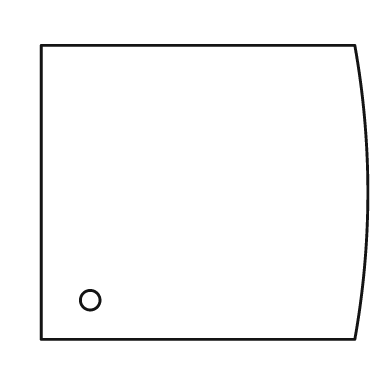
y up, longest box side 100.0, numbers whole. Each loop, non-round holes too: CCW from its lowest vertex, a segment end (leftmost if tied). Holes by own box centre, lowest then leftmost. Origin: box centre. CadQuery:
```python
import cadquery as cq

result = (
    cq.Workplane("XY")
    .moveTo(-50.0, -45.0)
    .lineTo(46.0, -45.0)
    .threePointArc((50.0, 0.0), (46.0, 45.0))
    .lineTo(-50.0, 45.0)
    .close()
    .moveTo(-35.0, -33.0)
    .circle(3.0)
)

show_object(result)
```